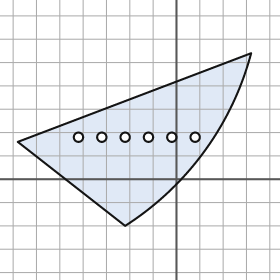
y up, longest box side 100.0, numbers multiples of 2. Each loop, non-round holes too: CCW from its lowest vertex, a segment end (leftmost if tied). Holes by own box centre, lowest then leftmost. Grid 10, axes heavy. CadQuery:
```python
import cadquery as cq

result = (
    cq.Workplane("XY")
    .moveTo(-22.0, -20.0)
    .threePointArc((12.0, 12.0), (32.0, 54.0))
    .lineTo(-68.0, 16.0)
    .close()
    .moveTo(-42.0, 18.0)
    .circle(2.0)
    .moveTo(-32.0, 18.0)
    .circle(2.0)
    .moveTo(-22.0, 18.0)
    .circle(2.0)
    .moveTo(-12.0, 18.0)
    .circle(2.0)
    .moveTo(-2.0, 18.0)
    .circle(2.0)
    .moveTo(8.0, 18.0)
    .circle(2.0)
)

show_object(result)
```